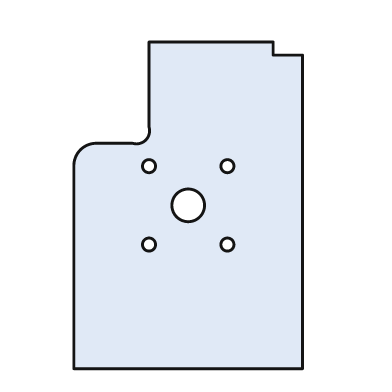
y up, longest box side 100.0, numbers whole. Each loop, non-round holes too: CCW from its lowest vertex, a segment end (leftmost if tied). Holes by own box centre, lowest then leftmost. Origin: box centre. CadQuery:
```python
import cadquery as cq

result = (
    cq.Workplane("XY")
    .moveTo(-35.0, -50.0)
    .lineTo(35.0, -50.0)
    .lineTo(35.0, 46.0)
    .lineTo(26.0, 46.0)
    .lineTo(26.0, 50.0)
    .lineTo(-12.0, 50.0)
    .lineTo(-12.0, 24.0)
    .threePointArc((-13.0, 20.0), (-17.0, 19.0))
    .lineTo(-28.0, 19.0)
    .threePointArc((-33.0, 17.0), (-35.0, 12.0))
    .close()
    .moveTo(-12.0, -12.0)
    .circle(2.0)
    .moveTo(12.0, -12.0)
    .circle(2.0)
    .moveTo(0.0, 0.0)
    .circle(5.0)
    .moveTo(-12.0, 12.0)
    .circle(2.0)
    .moveTo(12.0, 12.0)
    .circle(2.0)
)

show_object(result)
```